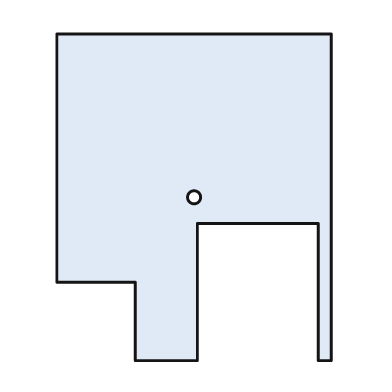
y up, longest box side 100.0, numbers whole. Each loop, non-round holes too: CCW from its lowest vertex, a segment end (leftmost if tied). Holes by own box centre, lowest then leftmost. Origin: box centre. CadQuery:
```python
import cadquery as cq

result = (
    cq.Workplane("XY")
    .moveTo(-18.0, -50.0)
    .lineTo(1.0, -50.0)
    .lineTo(1.0, -8.0)
    .lineTo(38.0, -8.0)
    .lineTo(38.0, -50.0)
    .lineTo(42.0, -50.0)
    .lineTo(42.0, 50.0)
    .lineTo(-42.0, 50.0)
    .lineTo(-42.0, -26.0)
    .lineTo(-18.0, -26.0)
    .close()
    .moveTo(0.0, 0.0)
    .circle(2.0)
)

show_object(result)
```